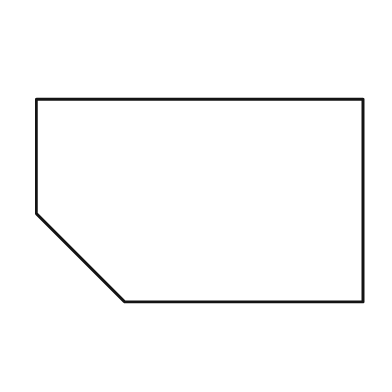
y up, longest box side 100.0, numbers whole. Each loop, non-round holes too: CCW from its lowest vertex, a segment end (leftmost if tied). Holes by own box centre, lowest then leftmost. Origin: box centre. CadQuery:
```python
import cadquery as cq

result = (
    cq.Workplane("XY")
    .moveTo(-23.0, -31.0)
    .lineTo(50.0, -31.0)
    .lineTo(50.0, 31.0)
    .lineTo(-50.0, 31.0)
    .lineTo(-50.0, -4.0)
    .close()
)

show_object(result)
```